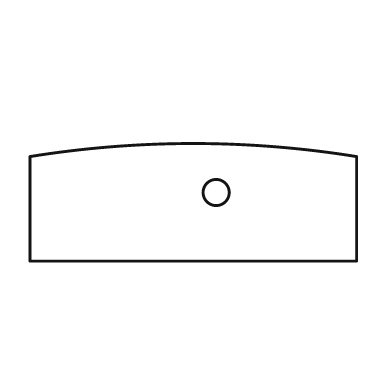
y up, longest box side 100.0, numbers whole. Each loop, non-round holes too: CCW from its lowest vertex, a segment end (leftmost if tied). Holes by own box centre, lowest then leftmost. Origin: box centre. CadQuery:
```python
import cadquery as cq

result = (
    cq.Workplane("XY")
    .moveTo(-50.0, -18.0)
    .lineTo(50.0, -18.0)
    .lineTo(50.0, 14.0)
    .threePointArc((0.0, 18.0), (-50.0, 14.0))
    .close()
    .moveTo(7.0, 3.0)
    .circle(4.0)
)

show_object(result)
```